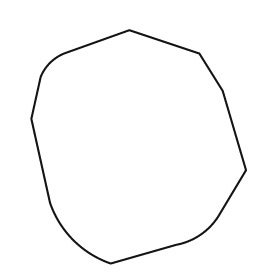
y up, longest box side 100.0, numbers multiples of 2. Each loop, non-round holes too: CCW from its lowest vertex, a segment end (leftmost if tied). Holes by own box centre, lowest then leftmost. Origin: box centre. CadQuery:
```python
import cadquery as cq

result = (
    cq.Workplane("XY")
    .moveTo(-12.0, -50.0)
    .lineTo(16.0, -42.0)
    .threePointArc((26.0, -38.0), (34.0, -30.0))
    .lineTo(46.0, -10.0)
    .lineTo(36.0, 24.0)
    .lineTo(26.0, 40.0)
    .lineTo(-4.0, 50.0)
    .lineTo(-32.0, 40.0)
    .threePointArc((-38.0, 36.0), (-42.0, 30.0))
    .lineTo(-46.0, 12.0)
    .lineTo(-38.0, -24.0)
    .threePointArc((-28.0, -40.0), (-12.0, -50.0))
    .close()
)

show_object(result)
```